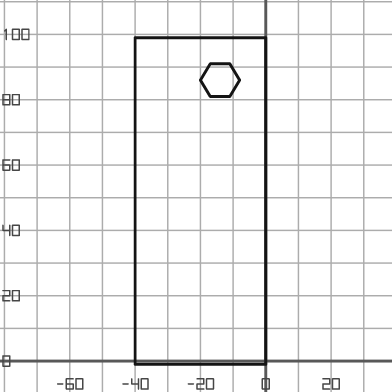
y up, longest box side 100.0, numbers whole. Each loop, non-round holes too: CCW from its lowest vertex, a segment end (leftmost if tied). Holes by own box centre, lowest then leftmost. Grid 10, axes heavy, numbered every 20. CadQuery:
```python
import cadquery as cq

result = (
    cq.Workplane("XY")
    .moveTo(-40.0, -1.0)
    .lineTo(0.0, -1.0)
    .lineTo(0.0, 99.0)
    .lineTo(-40.0, 99.0)
    .close()
    .moveTo(-17.0, 81.0)
    .lineTo(-11.0, 81.0)
    .lineTo(-8.0, 86.0)
    .lineTo(-11.0, 91.0)
    .lineTo(-17.0, 91.0)
    .lineTo(-20.0, 86.0)
    .close()
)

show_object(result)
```